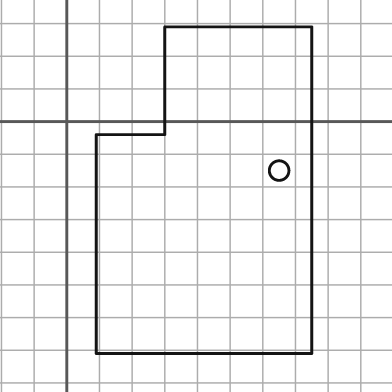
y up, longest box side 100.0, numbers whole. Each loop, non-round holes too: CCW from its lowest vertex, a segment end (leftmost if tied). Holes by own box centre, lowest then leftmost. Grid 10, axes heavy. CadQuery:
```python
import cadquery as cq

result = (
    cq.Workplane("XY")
    .moveTo(9.0, -71.0)
    .lineTo(75.0, -71.0)
    .lineTo(75.0, 29.0)
    .lineTo(30.0, 29.0)
    .lineTo(30.0, -4.0)
    .lineTo(9.0, -4.0)
    .close()
    .moveTo(65.0, -15.0)
    .circle(3.0)
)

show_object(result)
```